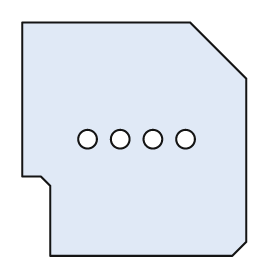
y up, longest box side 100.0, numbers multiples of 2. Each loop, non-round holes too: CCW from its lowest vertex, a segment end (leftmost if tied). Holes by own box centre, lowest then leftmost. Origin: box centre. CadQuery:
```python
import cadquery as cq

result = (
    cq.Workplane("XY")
    .moveTo(-36.0, -50.0)
    .lineTo(42.0, -50.0)
    .lineTo(48.0, -44.0)
    .lineTo(48.0, 26.0)
    .lineTo(24.0, 50.0)
    .lineTo(-48.0, 50.0)
    .lineTo(-48.0, -16.0)
    .lineTo(-40.0, -16.0)
    .lineTo(-36.0, -20.0)
    .close()
    .moveTo(-20.0, 0.0)
    .circle(4.0)
    .moveTo(-6.0, 0.0)
    .circle(4.0)
    .moveTo(8.0, 0.0)
    .circle(4.0)
    .moveTo(22.0, 0.0)
    .circle(4.0)
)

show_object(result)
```